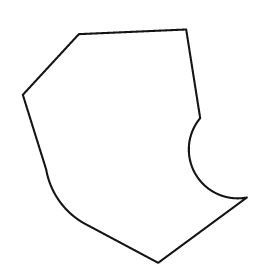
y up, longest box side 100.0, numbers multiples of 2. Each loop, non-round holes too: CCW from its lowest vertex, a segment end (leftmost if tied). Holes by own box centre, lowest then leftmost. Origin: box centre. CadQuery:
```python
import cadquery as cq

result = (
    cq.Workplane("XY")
    .moveTo(10.0, -50.0)
    .lineTo(48.0, -22.0)
    .threePointArc((26.0, -12.0), (28.0, 12.0))
    .lineTo(22.0, 50.0)
    .lineTo(-24.0, 48.0)
    .lineTo(-48.0, 22.0)
    .lineTo(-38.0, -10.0)
    .threePointArc((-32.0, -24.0), (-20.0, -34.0))
    .close()
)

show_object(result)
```